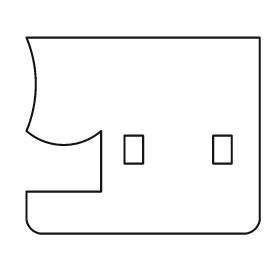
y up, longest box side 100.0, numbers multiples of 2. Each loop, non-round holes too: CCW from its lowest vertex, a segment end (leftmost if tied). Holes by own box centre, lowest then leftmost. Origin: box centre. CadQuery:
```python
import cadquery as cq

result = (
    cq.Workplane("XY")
    .moveTo(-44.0, -42.0)
    .lineTo(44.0, -42.0)
    .threePointArc((48.0, -40.0), (50.0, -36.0))
    .lineTo(50.0, 42.0)
    .lineTo(-50.0, 42.0)
    .threePointArc((-46.0, 22.0), (-50.0, 2.0))
    .threePointArc((-34.0, -4.0), (-18.0, 2.0))
    .lineTo(-18.0, -24.0)
    .lineTo(-50.0, -24.0)
    .lineTo(-50.0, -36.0)
    .threePointArc((-48.0, -40.0), (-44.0, -42.0))
    .close()
    .moveTo(-8.0, -12.0)
    .lineTo(0.0, -12.0)
    .lineTo(0.0, 0.0)
    .lineTo(-8.0, 0.0)
    .close()
    .moveTo(30.0, -12.0)
    .lineTo(38.0, -12.0)
    .lineTo(38.0, 0.0)
    .lineTo(30.0, 0.0)
    .close()
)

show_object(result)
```